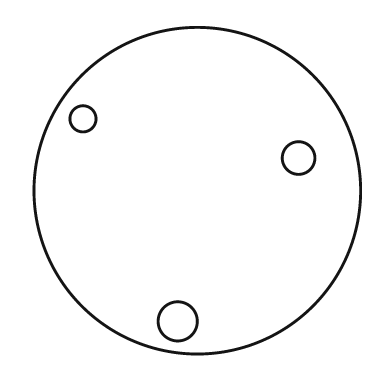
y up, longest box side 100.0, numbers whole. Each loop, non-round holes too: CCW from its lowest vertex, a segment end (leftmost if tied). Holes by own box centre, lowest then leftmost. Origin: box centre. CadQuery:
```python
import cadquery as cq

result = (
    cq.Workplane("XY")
    .moveTo(0.0, 0.0)
    .circle(50.0)
    .moveTo(-6.0, -40.0)
    .circle(6.0)
    .moveTo(31.0, 10.0)
    .circle(5.0)
    .moveTo(-35.0, 22.0)
    .circle(4.0)
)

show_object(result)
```